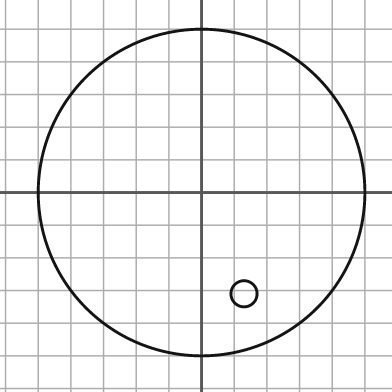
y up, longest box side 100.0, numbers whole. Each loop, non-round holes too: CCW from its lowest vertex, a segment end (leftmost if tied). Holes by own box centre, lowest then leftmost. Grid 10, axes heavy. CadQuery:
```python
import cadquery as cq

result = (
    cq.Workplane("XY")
    .moveTo(0.0, 0.0)
    .circle(50.0)
    .moveTo(13.0, -31.0)
    .circle(4.0)
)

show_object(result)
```